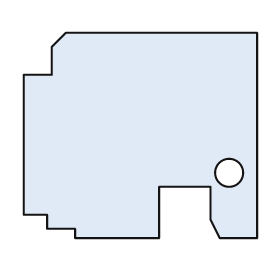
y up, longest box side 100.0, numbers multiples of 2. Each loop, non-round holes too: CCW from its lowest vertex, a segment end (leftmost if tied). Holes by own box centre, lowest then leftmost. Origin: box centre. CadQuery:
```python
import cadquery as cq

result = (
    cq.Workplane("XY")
    .moveTo(-28.0, -44.0)
    .lineTo(8.0, -44.0)
    .lineTo(8.0, -22.0)
    .lineTo(30.0, -22.0)
    .lineTo(30.0, -36.0)
    .lineTo(34.0, -44.0)
    .lineTo(50.0, -44.0)
    .lineTo(50.0, 44.0)
    .lineTo(-32.0, 44.0)
    .lineTo(-38.0, 38.0)
    .lineTo(-38.0, 26.0)
    .lineTo(-50.0, 26.0)
    .lineTo(-50.0, -34.0)
    .lineTo(-40.0, -34.0)
    .lineTo(-40.0, -40.0)
    .lineTo(-28.0, -40.0)
    .close()
    .moveTo(38.0, -16.0)
    .circle(6.0)
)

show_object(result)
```